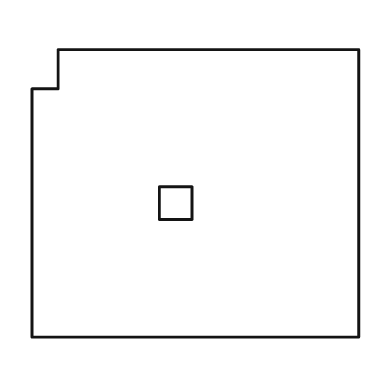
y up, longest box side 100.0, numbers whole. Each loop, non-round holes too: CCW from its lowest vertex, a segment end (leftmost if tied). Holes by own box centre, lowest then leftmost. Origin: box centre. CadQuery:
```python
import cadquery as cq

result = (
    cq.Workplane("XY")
    .moveTo(-50.0, -44.0)
    .lineTo(50.0, -44.0)
    .lineTo(50.0, 44.0)
    .lineTo(-42.0, 44.0)
    .lineTo(-42.0, 32.0)
    .lineTo(-50.0, 32.0)
    .close()
    .moveTo(-11.0, -8.0)
    .lineTo(-1.0, -8.0)
    .lineTo(-1.0, 2.0)
    .lineTo(-11.0, 2.0)
    .close()
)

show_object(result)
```